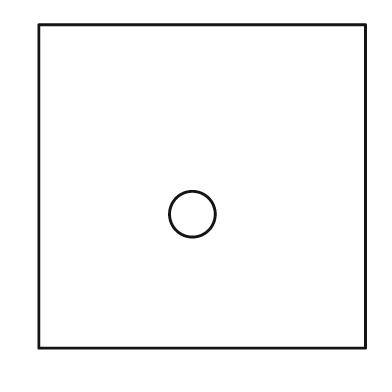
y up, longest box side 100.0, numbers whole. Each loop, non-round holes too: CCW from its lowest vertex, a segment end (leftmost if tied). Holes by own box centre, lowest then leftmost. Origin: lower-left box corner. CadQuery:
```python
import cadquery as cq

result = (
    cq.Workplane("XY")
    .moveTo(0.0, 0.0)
    .lineTo(100.0, 0.0)
    .lineTo(100.0, 99.0)
    .lineTo(0.0, 99.0)
    .close()
    .moveTo(47.0, 41.0)
    .circle(7.0)
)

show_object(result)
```